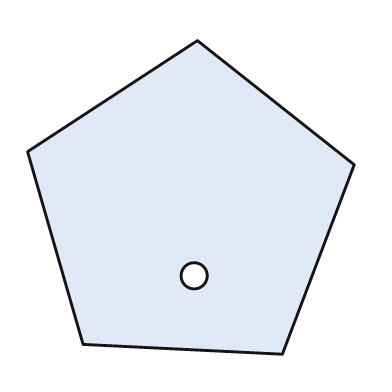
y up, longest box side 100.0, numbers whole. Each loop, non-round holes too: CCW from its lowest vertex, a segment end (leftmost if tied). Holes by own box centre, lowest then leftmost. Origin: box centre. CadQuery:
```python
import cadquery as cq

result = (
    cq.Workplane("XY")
    .moveTo(28.0, -48.0)
    .lineTo(50.0, 10.0)
    .lineTo(2.0, 48.0)
    .lineTo(-50.0, 14.0)
    .lineTo(-33.0, -45.0)
    .close()
    .moveTo(1.0, -24.0)
    .circle(4.0)
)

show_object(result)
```